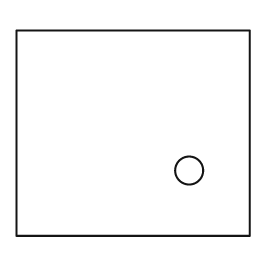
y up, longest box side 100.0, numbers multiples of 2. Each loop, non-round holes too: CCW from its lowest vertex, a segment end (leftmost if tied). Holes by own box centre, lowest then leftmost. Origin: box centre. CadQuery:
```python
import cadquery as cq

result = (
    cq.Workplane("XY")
    .moveTo(-50.0, -44.0)
    .lineTo(50.0, -44.0)
    .lineTo(50.0, 44.0)
    .lineTo(-50.0, 44.0)
    .close()
    .moveTo(24.0, -16.0)
    .circle(6.0)
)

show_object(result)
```